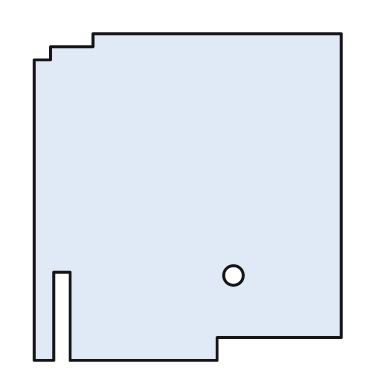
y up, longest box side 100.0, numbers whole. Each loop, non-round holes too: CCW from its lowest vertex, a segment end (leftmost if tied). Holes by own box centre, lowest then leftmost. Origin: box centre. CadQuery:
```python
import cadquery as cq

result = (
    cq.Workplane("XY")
    .moveTo(-47.0, -50.0)
    .lineTo(-41.0, -50.0)
    .lineTo(-41.0, -23.0)
    .lineTo(-36.0, -23.0)
    .lineTo(-36.0, -50.0)
    .lineTo(9.0, -50.0)
    .lineTo(9.0, -43.0)
    .lineTo(47.0, -43.0)
    .lineTo(47.0, 50.0)
    .lineTo(-29.0, 50.0)
    .lineTo(-29.0, 46.0)
    .lineTo(-42.0, 46.0)
    .lineTo(-42.0, 42.0)
    .lineTo(-47.0, 42.0)
    .close()
    .moveTo(14.0, -24.0)
    .circle(3.0)
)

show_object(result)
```